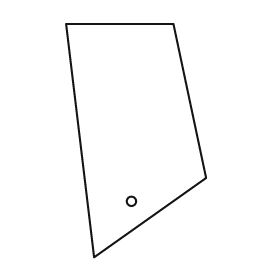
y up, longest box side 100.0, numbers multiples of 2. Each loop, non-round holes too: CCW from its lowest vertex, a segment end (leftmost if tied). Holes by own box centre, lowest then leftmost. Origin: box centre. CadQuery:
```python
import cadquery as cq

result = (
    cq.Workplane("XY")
    .moveTo(-18.0, -50.0)
    .lineTo(30.0, -16.0)
    .lineTo(16.0, 50.0)
    .lineTo(-30.0, 50.0)
    .close()
    .moveTo(-2.0, -26.0)
    .circle(2.0)
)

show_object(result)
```